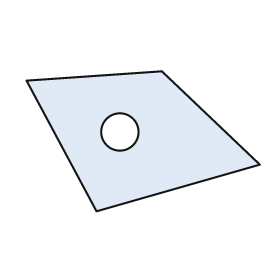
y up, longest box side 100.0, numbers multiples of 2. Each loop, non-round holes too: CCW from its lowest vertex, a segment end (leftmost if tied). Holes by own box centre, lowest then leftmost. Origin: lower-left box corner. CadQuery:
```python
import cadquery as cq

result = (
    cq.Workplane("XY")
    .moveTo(30.0, 0.0)
    .lineTo(100.0, 20.0)
    .lineTo(58.0, 60.0)
    .lineTo(0.0, 56.0)
    .close()
    .moveTo(40.0, 34.0)
    .circle(8.0)
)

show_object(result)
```